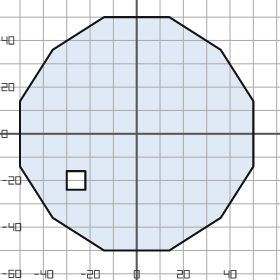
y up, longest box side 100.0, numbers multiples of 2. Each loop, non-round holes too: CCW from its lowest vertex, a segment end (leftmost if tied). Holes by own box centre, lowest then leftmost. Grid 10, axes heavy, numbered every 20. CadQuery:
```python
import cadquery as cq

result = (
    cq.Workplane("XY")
    .moveTo(-14.0, -50.0)
    .lineTo(14.0, -50.0)
    .lineTo(36.0, -36.0)
    .lineTo(50.0, -14.0)
    .lineTo(50.0, 14.0)
    .lineTo(36.0, 36.0)
    .lineTo(14.0, 50.0)
    .lineTo(-14.0, 50.0)
    .lineTo(-36.0, 36.0)
    .lineTo(-50.0, 14.0)
    .lineTo(-50.0, -14.0)
    .lineTo(-36.0, -36.0)
    .close()
    .moveTo(-30.0, -24.0)
    .lineTo(-22.0, -24.0)
    .lineTo(-22.0, -16.0)
    .lineTo(-30.0, -16.0)
    .close()
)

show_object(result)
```